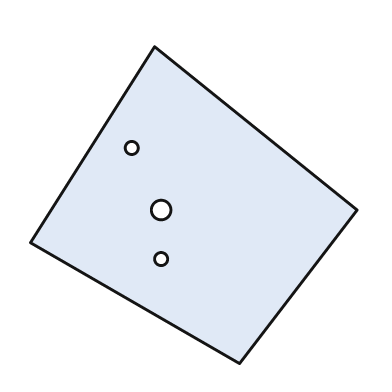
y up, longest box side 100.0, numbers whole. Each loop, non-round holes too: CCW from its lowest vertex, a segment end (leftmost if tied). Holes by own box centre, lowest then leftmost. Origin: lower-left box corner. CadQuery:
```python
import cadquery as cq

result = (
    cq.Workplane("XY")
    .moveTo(64.0, 0.0)
    .lineTo(100.0, 47.0)
    .lineTo(38.0, 97.0)
    .lineTo(0.0, 37.0)
    .close()
    .moveTo(40.0, 32.0)
    .circle(2.0)
    .moveTo(40.0, 47.0)
    .circle(3.0)
    .moveTo(31.0, 66.0)
    .circle(2.0)
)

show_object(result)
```